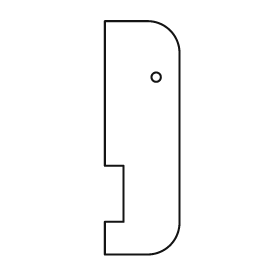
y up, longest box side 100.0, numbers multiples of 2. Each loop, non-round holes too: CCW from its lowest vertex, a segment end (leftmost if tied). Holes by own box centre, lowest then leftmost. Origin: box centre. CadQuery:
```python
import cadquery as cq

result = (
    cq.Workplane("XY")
    .moveTo(-16.0, -50.0)
    .lineTo(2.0, -50.0)
    .threePointArc((12.0, -46.0), (16.0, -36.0))
    .lineTo(16.0, 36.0)
    .threePointArc((12.0, 46.0), (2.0, 50.0))
    .lineTo(-16.0, 50.0)
    .lineTo(-16.0, -12.0)
    .lineTo(-8.0, -12.0)
    .lineTo(-8.0, -36.0)
    .lineTo(-16.0, -36.0)
    .close()
    .moveTo(6.0, 26.0)
    .circle(2.0)
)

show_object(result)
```